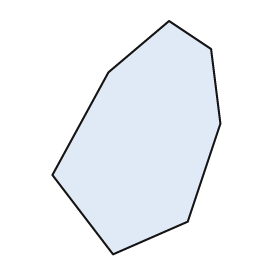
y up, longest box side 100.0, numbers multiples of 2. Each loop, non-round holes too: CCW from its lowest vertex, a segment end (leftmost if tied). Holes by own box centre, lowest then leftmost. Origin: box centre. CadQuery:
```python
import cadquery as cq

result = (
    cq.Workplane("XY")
    .moveTo(-10.0, -50.0)
    .lineTo(22.0, -36.0)
    .lineTo(36.0, 6.0)
    .lineTo(32.0, 38.0)
    .lineTo(14.0, 50.0)
    .lineTo(-12.0, 28.0)
    .lineTo(-36.0, -16.0)
    .close()
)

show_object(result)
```